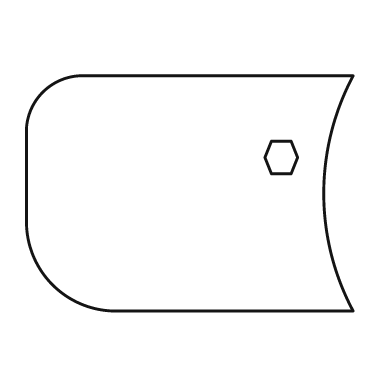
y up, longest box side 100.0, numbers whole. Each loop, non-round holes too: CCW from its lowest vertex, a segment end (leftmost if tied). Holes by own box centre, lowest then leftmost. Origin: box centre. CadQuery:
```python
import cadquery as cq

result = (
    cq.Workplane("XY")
    .moveTo(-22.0, -36.0)
    .lineTo(50.0, -36.0)
    .threePointArc((41.0, 0.0), (50.0, 36.0))
    .lineTo(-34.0, 36.0)
    .threePointArc((-45.0, 31.0), (-50.0, 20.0))
    .lineTo(-50.0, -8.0)
    .threePointArc((-42.0, -28.0), (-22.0, -36.0))
    .close()
    .moveTo(25.0, 6.0)
    .lineTo(31.0, 6.0)
    .lineTo(33.0, 11.0)
    .lineTo(31.0, 16.0)
    .lineTo(25.0, 16.0)
    .lineTo(23.0, 11.0)
    .close()
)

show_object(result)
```